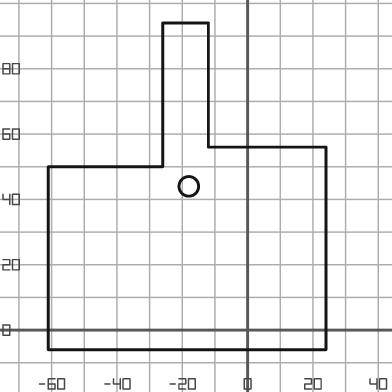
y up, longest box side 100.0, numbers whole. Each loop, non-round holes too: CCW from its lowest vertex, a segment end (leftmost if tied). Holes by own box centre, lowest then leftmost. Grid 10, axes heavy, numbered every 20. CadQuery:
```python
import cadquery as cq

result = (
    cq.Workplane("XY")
    .moveTo(-61.0, -6.0)
    .lineTo(24.0, -6.0)
    .lineTo(24.0, 56.0)
    .lineTo(-12.0, 56.0)
    .lineTo(-12.0, 94.0)
    .lineTo(-26.0, 94.0)
    .lineTo(-26.0, 50.0)
    .lineTo(-61.0, 50.0)
    .close()
    .moveTo(-18.0, 44.0)
    .circle(3.0)
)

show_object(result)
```